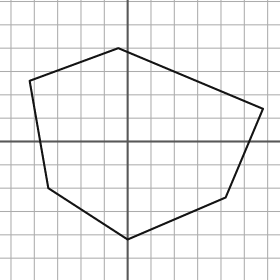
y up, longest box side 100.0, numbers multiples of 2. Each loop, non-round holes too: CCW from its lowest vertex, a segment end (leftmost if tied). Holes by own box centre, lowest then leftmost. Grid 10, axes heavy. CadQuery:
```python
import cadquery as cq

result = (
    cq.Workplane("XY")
    .moveTo(0.0, -42.0)
    .lineTo(42.0, -24.0)
    .lineTo(58.0, 14.0)
    .lineTo(-4.0, 40.0)
    .lineTo(-42.0, 26.0)
    .lineTo(-34.0, -20.0)
    .close()
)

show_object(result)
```